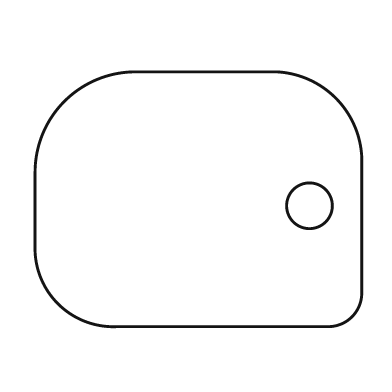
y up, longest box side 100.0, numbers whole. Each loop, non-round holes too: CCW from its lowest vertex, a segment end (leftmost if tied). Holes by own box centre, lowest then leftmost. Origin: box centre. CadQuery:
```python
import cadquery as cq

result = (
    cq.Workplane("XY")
    .moveTo(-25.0, -39.0)
    .lineTo(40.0, -39.0)
    .threePointArc((47.0, -36.0), (50.0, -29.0))
    .lineTo(50.0, 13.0)
    .threePointArc((42.0, 31.0), (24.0, 39.0))
    .lineTo(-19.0, 39.0)
    .threePointArc((-41.0, 30.0), (-50.0, 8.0))
    .lineTo(-50.0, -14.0)
    .threePointArc((-43.0, -32.0), (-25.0, -39.0))
    .close()
    .moveTo(34.0, -2.0)
    .circle(7.0)
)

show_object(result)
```